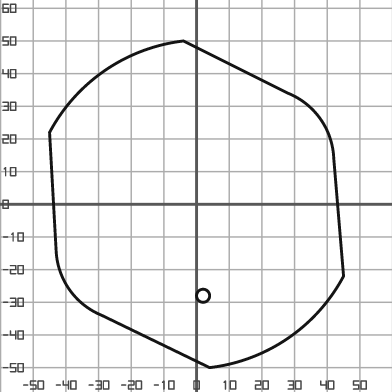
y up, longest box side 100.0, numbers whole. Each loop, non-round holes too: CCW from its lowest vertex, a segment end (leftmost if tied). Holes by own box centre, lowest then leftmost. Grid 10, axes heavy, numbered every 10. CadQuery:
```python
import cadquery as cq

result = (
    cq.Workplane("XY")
    .moveTo(4.0, -50.0)
    .threePointArc((28.0, -41.0), (45.0, -22.0))
    .lineTo(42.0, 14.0)
    .threePointArc((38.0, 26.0), (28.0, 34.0))
    .lineTo(-4.0, 50.0)
    .threePointArc((-28.0, 41.0), (-45.0, 22.0))
    .lineTo(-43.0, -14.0)
    .threePointArc((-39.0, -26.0), (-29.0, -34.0))
    .close()
    .moveTo(2.0, -28.0)
    .circle(2.0)
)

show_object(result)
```